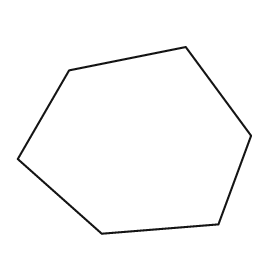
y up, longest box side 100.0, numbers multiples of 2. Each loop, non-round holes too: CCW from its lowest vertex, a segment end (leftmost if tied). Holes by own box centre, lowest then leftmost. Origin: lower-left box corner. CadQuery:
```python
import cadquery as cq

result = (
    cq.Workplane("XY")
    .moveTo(36.0, 0.0)
    .lineTo(86.0, 4.0)
    .lineTo(100.0, 42.0)
    .lineTo(72.0, 80.0)
    .lineTo(22.0, 70.0)
    .lineTo(0.0, 32.0)
    .close()
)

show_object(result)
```